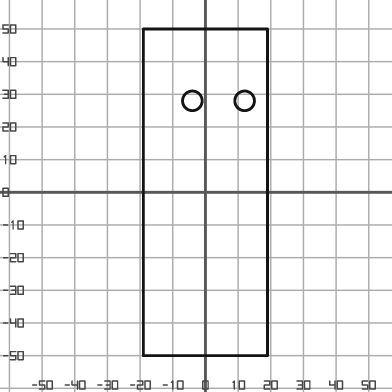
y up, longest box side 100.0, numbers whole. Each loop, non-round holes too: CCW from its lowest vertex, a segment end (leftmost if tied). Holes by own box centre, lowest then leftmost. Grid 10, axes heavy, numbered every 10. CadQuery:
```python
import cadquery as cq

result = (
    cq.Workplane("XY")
    .moveTo(-19.0, -50.0)
    .lineTo(19.0, -50.0)
    .lineTo(19.0, 50.0)
    .lineTo(-19.0, 50.0)
    .close()
    .moveTo(-4.0, 28.0)
    .circle(3.0)
    .moveTo(12.0, 28.0)
    .circle(3.0)
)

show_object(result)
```